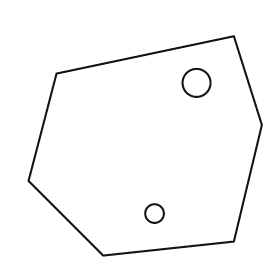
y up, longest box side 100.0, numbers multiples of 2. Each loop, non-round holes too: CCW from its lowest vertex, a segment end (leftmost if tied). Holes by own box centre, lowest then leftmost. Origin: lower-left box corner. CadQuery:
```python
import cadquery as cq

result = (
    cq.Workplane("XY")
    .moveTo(32.0, 0.0)
    .lineTo(88.0, 6.0)
    .lineTo(100.0, 56.0)
    .lineTo(88.0, 94.0)
    .lineTo(12.0, 78.0)
    .lineTo(0.0, 32.0)
    .close()
    .moveTo(54.0, 18.0)
    .circle(4.0)
    .moveTo(72.0, 74.0)
    .circle(6.0)
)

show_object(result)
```